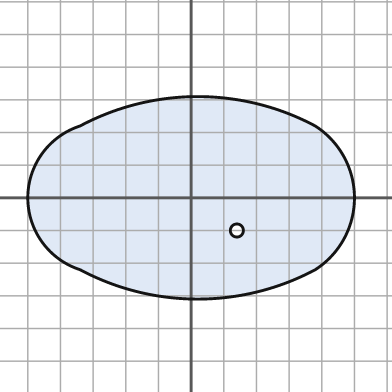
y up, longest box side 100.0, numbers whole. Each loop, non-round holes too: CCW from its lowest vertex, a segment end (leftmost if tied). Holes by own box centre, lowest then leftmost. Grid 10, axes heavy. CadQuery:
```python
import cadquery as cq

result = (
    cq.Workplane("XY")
    .moveTo(-34.0, -22.0)
    .threePointArc((2.0, -31.0), (38.0, -22.0))
    .threePointArc((50.0, 0.0), (38.0, 22.0))
    .threePointArc((2.0, 31.0), (-34.0, 22.0))
    .threePointArc((-50.0, 0.0), (-34.0, -22.0))
    .close()
    .moveTo(14.0, -10.0)
    .circle(2.0)
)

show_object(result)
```